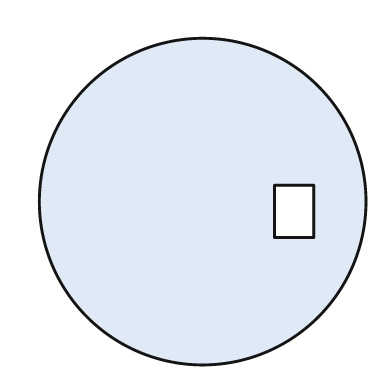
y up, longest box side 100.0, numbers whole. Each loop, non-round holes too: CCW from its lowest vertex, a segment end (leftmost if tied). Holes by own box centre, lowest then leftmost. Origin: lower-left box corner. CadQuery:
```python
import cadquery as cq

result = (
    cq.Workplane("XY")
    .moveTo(50.0, 50.0)
    .circle(50.0)
    .moveTo(72.0, 39.0)
    .lineTo(84.0, 39.0)
    .lineTo(84.0, 55.0)
    .lineTo(72.0, 55.0)
    .close()
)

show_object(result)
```